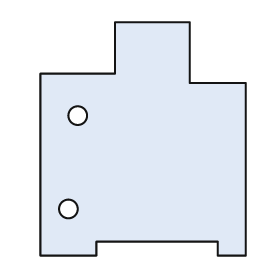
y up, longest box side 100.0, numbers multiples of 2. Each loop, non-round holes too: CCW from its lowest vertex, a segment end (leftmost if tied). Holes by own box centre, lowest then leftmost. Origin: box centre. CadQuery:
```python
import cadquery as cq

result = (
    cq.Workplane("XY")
    .moveTo(-44.0, -50.0)
    .lineTo(-20.0, -50.0)
    .lineTo(-20.0, -44.0)
    .lineTo(32.0, -44.0)
    .lineTo(32.0, -50.0)
    .lineTo(44.0, -50.0)
    .lineTo(44.0, 24.0)
    .lineTo(20.0, 24.0)
    .lineTo(20.0, 50.0)
    .lineTo(-12.0, 50.0)
    .lineTo(-12.0, 28.0)
    .lineTo(-44.0, 28.0)
    .close()
    .moveTo(-32.0, -30.0)
    .circle(4.0)
    .moveTo(-28.0, 10.0)
    .circle(4.0)
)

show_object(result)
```